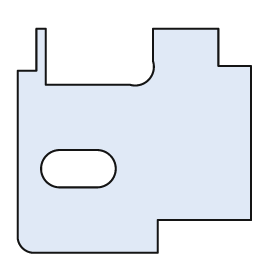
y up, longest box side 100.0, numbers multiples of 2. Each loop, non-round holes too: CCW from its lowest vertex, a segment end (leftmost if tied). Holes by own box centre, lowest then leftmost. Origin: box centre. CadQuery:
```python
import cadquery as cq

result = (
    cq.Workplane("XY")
    .moveTo(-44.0, -48.0)
    .lineTo(10.0, -48.0)
    .lineTo(10.0, -34.0)
    .lineTo(50.0, -34.0)
    .lineTo(50.0, 32.0)
    .lineTo(36.0, 32.0)
    .lineTo(36.0, 48.0)
    .lineTo(8.0, 48.0)
    .lineTo(8.0, 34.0)
    .threePointArc((6.0, 26.0), (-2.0, 24.0))
    .lineTo(-38.0, 24.0)
    .lineTo(-38.0, 48.0)
    .lineTo(-42.0, 48.0)
    .lineTo(-42.0, 30.0)
    .lineTo(-50.0, 30.0)
    .lineTo(-50.0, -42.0)
    .threePointArc((-48.0, -46.0), (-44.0, -48.0))
    .close()
    .moveTo(-32.0, -20.0)
    .lineTo(-16.0, -20.0)
    .threePointArc((-8.0, -12.0), (-16.0, -4.0))
    .lineTo(-32.0, -4.0)
    .threePointArc((-40.0, -12.0), (-32.0, -20.0))
    .close()
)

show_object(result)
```